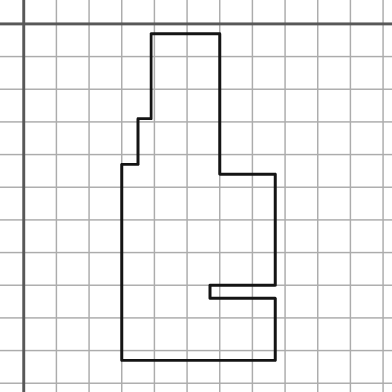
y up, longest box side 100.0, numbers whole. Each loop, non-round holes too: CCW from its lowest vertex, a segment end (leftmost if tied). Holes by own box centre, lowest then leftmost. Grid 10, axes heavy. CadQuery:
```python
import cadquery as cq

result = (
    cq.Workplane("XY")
    .moveTo(30.0, -103.0)
    .lineTo(77.0, -103.0)
    .lineTo(77.0, -84.0)
    .lineTo(57.0, -84.0)
    .lineTo(57.0, -80.0)
    .lineTo(77.0, -80.0)
    .lineTo(77.0, -46.0)
    .lineTo(60.0, -46.0)
    .lineTo(60.0, -3.0)
    .lineTo(39.0, -3.0)
    .lineTo(39.0, -29.0)
    .lineTo(35.0, -29.0)
    .lineTo(35.0, -43.0)
    .lineTo(30.0, -43.0)
    .close()
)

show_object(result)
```